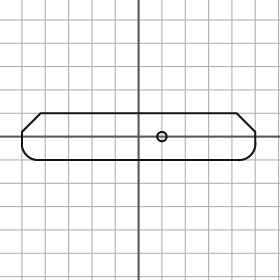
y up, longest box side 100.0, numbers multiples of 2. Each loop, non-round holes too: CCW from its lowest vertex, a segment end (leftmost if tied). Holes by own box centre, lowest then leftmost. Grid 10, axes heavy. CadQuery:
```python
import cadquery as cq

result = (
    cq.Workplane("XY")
    .moveTo(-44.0, -10.0)
    .lineTo(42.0, -10.0)
    .threePointArc((48.0, -8.0), (50.0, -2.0))
    .lineTo(50.0, 2.0)
    .lineTo(42.0, 10.0)
    .lineTo(-42.0, 10.0)
    .lineTo(-50.0, 2.0)
    .lineTo(-50.0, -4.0)
    .threePointArc((-48.0, -8.0), (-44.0, -10.0))
    .close()
    .moveTo(10.0, 0.0)
    .circle(2.0)
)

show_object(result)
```